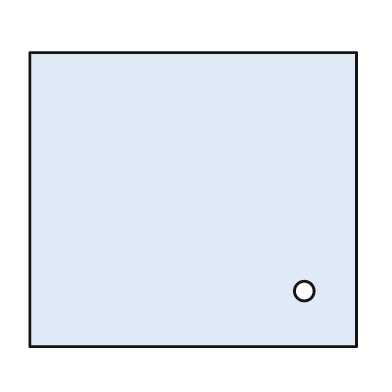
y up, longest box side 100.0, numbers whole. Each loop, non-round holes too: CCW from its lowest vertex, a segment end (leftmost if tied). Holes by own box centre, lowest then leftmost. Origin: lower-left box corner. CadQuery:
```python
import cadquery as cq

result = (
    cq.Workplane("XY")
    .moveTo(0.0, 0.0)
    .lineTo(100.0, 0.0)
    .lineTo(100.0, 90.0)
    .lineTo(0.0, 90.0)
    .close()
    .moveTo(84.0, 17.0)
    .circle(3.0)
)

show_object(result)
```